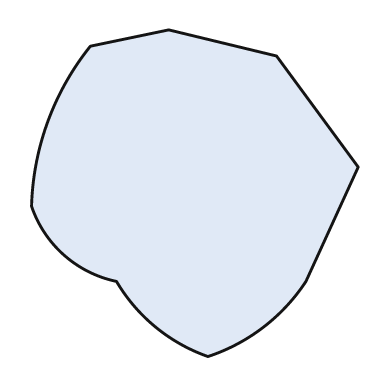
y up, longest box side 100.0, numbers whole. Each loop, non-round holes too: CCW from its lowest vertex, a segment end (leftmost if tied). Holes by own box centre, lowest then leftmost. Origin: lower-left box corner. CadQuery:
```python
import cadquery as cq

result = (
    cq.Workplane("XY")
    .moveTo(54.0, 0.0)
    .threePointArc((71.0, 9.0), (84.0, 23.0))
    .lineTo(100.0, 58.0)
    .lineTo(75.0, 92.0)
    .lineTo(42.0, 100.0)
    .lineTo(18.0, 95.0)
    .threePointArc((5.0, 72.0), (0.0, 46.0))
    .threePointArc((10.0, 31.0), (26.0, 23.0))
    .threePointArc((38.0, 9.0), (54.0, 0.0))
    .close()
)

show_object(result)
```